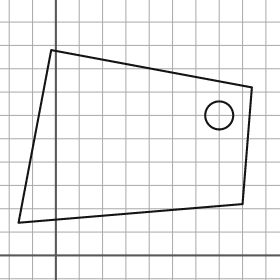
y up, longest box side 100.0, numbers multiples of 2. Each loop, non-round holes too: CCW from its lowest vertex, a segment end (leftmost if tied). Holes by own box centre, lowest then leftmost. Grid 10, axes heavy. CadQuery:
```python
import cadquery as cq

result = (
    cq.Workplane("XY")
    .moveTo(-16.0, 14.0)
    .lineTo(80.0, 22.0)
    .lineTo(84.0, 72.0)
    .lineTo(-2.0, 88.0)
    .close()
    .moveTo(70.0, 60.0)
    .circle(6.0)
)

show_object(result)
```